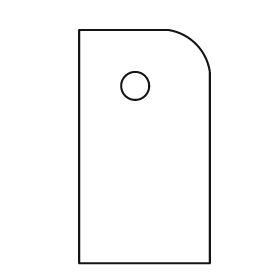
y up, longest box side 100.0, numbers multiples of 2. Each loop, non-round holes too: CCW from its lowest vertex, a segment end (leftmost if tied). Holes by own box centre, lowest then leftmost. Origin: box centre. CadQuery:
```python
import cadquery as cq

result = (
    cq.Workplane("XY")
    .moveTo(-28.0, -50.0)
    .lineTo(28.0, -50.0)
    .lineTo(28.0, 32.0)
    .threePointArc((22.0, 44.0), (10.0, 50.0))
    .lineTo(-28.0, 50.0)
    .close()
    .moveTo(-4.0, 26.0)
    .circle(6.0)
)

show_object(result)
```